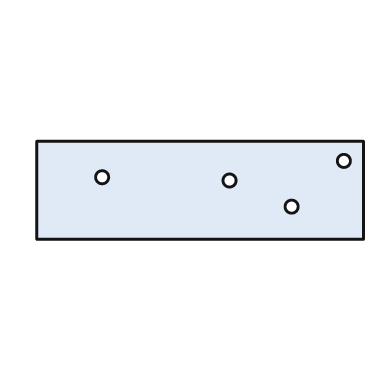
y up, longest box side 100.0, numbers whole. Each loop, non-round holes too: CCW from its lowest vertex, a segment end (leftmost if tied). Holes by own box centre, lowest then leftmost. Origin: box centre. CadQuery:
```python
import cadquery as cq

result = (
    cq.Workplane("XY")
    .moveTo(-50.0, -15.0)
    .lineTo(50.0, -15.0)
    .lineTo(50.0, 15.0)
    .lineTo(-50.0, 15.0)
    .close()
    .moveTo(28.0, -5.0)
    .circle(2.0)
    .moveTo(9.0, 3.0)
    .circle(2.0)
    .moveTo(-30.0, 4.0)
    .circle(2.0)
    .moveTo(44.0, 9.0)
    .circle(2.0)
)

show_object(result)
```